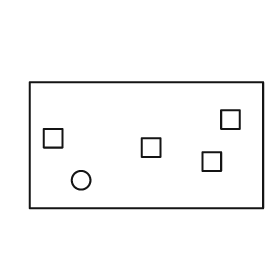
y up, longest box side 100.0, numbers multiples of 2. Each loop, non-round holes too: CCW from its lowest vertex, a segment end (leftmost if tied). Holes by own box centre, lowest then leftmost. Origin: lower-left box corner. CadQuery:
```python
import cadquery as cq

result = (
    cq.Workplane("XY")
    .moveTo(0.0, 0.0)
    .lineTo(100.0, 0.0)
    .lineTo(100.0, 54.0)
    .lineTo(0.0, 54.0)
    .close()
    .moveTo(22.0, 12.0)
    .circle(4.0)
    .moveTo(74.0, 16.0)
    .lineTo(82.0, 16.0)
    .lineTo(82.0, 24.0)
    .lineTo(74.0, 24.0)
    .close()
    .moveTo(48.0, 22.0)
    .lineTo(56.0, 22.0)
    .lineTo(56.0, 30.0)
    .lineTo(48.0, 30.0)
    .close()
    .moveTo(6.0, 26.0)
    .lineTo(14.0, 26.0)
    .lineTo(14.0, 34.0)
    .lineTo(6.0, 34.0)
    .close()
    .moveTo(82.0, 34.0)
    .lineTo(90.0, 34.0)
    .lineTo(90.0, 42.0)
    .lineTo(82.0, 42.0)
    .close()
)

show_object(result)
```